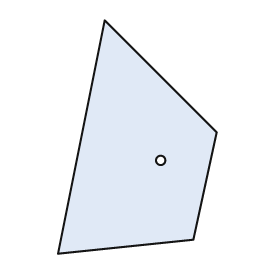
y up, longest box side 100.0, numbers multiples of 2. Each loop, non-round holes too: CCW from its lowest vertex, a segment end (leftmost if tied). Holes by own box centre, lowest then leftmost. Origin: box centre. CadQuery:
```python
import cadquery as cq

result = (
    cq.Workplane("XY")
    .moveTo(-34.0, -50.0)
    .lineTo(24.0, -44.0)
    .lineTo(34.0, 2.0)
    .lineTo(-14.0, 50.0)
    .close()
    .moveTo(10.0, -10.0)
    .circle(2.0)
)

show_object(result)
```